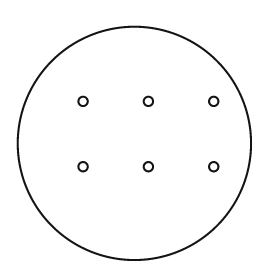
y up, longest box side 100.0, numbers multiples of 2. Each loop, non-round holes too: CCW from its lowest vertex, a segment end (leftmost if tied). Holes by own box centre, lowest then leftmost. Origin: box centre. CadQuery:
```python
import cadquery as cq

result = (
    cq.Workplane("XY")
    .moveTo(0.0, 0.0)
    .circle(50.0)
    .moveTo(-22.0, -10.0)
    .circle(2.0)
    .moveTo(6.0, -10.0)
    .circle(2.0)
    .moveTo(34.0, -10.0)
    .circle(2.0)
    .moveTo(-22.0, 18.0)
    .circle(2.0)
    .moveTo(6.0, 18.0)
    .circle(2.0)
    .moveTo(34.0, 18.0)
    .circle(2.0)
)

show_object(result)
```